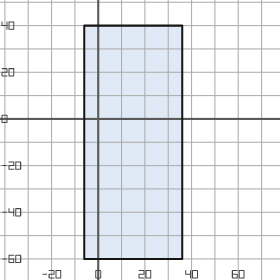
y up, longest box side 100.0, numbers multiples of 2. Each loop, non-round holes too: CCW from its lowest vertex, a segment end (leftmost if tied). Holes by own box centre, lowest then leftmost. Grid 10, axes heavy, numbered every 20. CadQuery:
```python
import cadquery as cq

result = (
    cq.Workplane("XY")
    .moveTo(-6.0, -60.0)
    .lineTo(36.0, -60.0)
    .lineTo(36.0, 40.0)
    .lineTo(-6.0, 40.0)
    .close()
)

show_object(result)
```